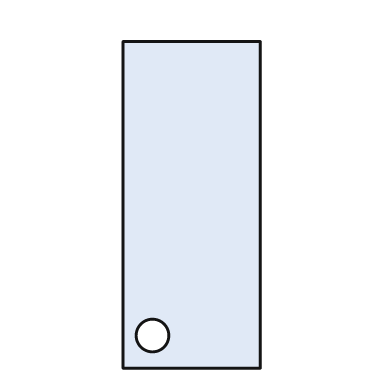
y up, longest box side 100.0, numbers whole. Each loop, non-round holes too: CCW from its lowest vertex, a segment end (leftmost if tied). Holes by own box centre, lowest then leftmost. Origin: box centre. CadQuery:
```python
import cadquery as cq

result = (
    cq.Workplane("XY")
    .moveTo(-21.0, -50.0)
    .lineTo(21.0, -50.0)
    .lineTo(21.0, 50.0)
    .lineTo(-21.0, 50.0)
    .close()
    .moveTo(-12.0, -40.0)
    .circle(5.0)
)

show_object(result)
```